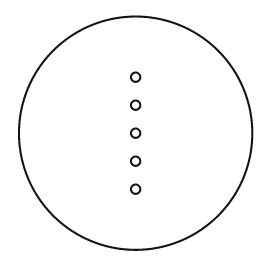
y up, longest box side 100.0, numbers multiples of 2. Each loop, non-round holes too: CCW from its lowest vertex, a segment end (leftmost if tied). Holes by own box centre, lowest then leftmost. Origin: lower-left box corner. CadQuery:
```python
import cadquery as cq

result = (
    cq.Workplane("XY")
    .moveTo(50.0, 50.0)
    .circle(50.0)
    .moveTo(50.0, 26.0)
    .circle(2.0)
    .moveTo(50.0, 38.0)
    .circle(2.0)
    .moveTo(50.0, 50.0)
    .circle(2.0)
    .moveTo(50.0, 62.0)
    .circle(2.0)
    .moveTo(50.0, 74.0)
    .circle(2.0)
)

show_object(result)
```